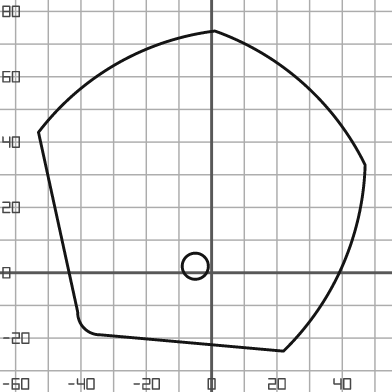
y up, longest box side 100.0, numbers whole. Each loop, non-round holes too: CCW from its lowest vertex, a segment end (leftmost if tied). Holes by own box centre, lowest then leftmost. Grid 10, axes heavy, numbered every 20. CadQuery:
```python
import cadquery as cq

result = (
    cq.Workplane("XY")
    .moveTo(22.0, -24.0)
    .threePointArc((40.0, 2.0), (47.0, 33.0))
    .threePointArc((28.0, 58.0), (1.0, 74.0))
    .threePointArc((-29.0, 64.0), (-53.0, 43.0))
    .lineTo(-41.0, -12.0)
    .threePointArc((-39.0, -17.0), (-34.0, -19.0))
    .close()
    .moveTo(-5.0, 2.0)
    .circle(4.0)
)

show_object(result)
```